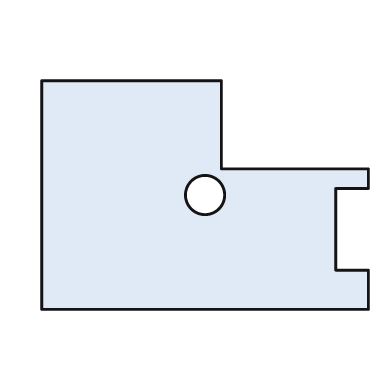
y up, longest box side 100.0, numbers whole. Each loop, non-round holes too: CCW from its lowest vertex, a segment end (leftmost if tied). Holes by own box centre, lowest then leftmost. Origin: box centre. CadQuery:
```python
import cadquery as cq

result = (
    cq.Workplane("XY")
    .moveTo(-50.0, -35.0)
    .lineTo(50.0, -35.0)
    .lineTo(50.0, -23.0)
    .lineTo(40.0, -23.0)
    .lineTo(40.0, 2.0)
    .lineTo(50.0, 2.0)
    .lineTo(50.0, 8.0)
    .lineTo(5.0, 8.0)
    .lineTo(5.0, 35.0)
    .lineTo(-50.0, 35.0)
    .close()
    .moveTo(0.0, 0.0)
    .circle(6.0)
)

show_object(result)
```